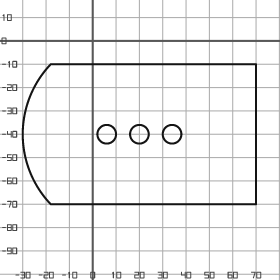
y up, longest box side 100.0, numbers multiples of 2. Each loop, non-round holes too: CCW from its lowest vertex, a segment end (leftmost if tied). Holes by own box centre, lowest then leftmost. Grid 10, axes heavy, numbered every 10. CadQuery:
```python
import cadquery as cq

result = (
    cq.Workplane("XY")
    .moveTo(-18.0, -70.0)
    .lineTo(70.0, -70.0)
    .lineTo(70.0, -10.0)
    .lineTo(-18.0, -10.0)
    .threePointArc((-30.0, -40.0), (-18.0, -70.0))
    .close()
    .moveTo(6.0, -40.0)
    .circle(4.0)
    .moveTo(20.0, -40.0)
    .circle(4.0)
    .moveTo(34.0, -40.0)
    .circle(4.0)
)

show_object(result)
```